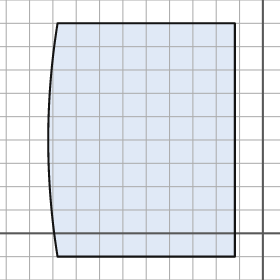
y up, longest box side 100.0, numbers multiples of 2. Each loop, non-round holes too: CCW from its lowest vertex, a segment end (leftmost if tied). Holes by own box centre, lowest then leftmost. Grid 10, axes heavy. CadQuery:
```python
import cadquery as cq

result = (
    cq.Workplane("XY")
    .moveTo(-88.0, -10.0)
    .lineTo(-12.0, -10.0)
    .lineTo(-12.0, 90.0)
    .lineTo(-88.0, 90.0)
    .threePointArc((-92.0, 40.0), (-88.0, -10.0))
    .close()
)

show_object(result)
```